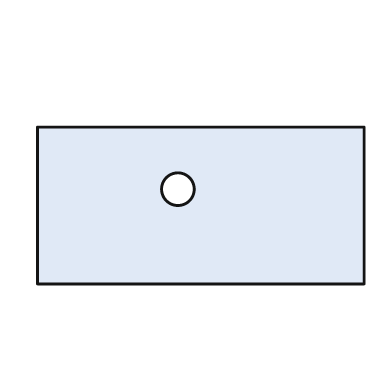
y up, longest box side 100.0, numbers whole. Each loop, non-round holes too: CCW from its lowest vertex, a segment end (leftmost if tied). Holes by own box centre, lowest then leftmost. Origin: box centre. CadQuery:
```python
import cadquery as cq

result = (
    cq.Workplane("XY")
    .moveTo(-50.0, -24.0)
    .lineTo(50.0, -24.0)
    .lineTo(50.0, 24.0)
    .lineTo(-50.0, 24.0)
    .close()
    .moveTo(-7.0, 5.0)
    .circle(5.0)
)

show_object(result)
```